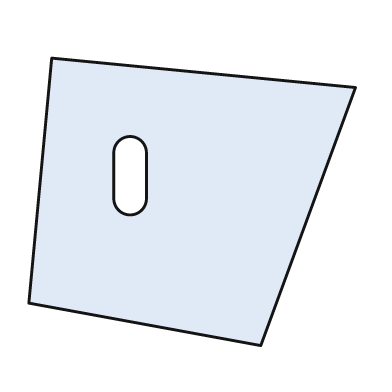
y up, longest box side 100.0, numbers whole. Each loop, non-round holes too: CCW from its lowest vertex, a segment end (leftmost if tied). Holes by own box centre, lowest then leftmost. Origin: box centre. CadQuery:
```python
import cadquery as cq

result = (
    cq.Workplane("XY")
    .moveTo(21.0, -44.0)
    .lineTo(50.0, 35.0)
    .lineTo(-43.0, 44.0)
    .lineTo(-50.0, -31.0)
    .close()
    .moveTo(-24.0, 1.0)
    .threePointArc((-19.0, -4.0), (-14.0, 1.0))
    .lineTo(-14.0, 15.0)
    .threePointArc((-19.0, 20.0), (-24.0, 15.0))
    .close()
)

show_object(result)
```